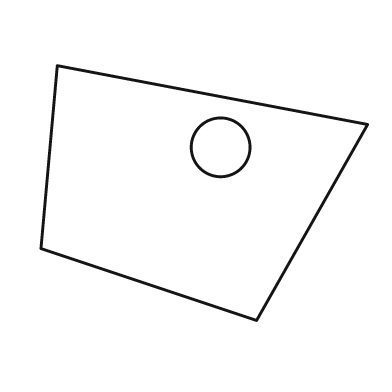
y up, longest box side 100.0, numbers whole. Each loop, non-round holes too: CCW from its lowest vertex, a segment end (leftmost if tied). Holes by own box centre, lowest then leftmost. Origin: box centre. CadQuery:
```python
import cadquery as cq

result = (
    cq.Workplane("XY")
    .moveTo(16.0, -39.0)
    .lineTo(50.0, 21.0)
    .lineTo(-45.0, 39.0)
    .lineTo(-50.0, -17.0)
    .close()
    .moveTo(5.0, 14.0)
    .circle(9.0)
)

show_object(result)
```